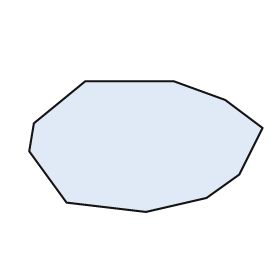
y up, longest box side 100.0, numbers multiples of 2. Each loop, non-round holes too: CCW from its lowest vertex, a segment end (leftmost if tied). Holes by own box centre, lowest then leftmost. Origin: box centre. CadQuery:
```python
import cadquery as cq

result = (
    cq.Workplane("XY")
    .moveTo(0.0, -28.0)
    .lineTo(26.0, -22.0)
    .lineTo(40.0, -12.0)
    .lineTo(50.0, 8.0)
    .lineTo(34.0, 20.0)
    .lineTo(12.0, 28.0)
    .lineTo(-26.0, 28.0)
    .lineTo(-48.0, 10.0)
    .lineTo(-50.0, -2.0)
    .lineTo(-34.0, -24.0)
    .close()
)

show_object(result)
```